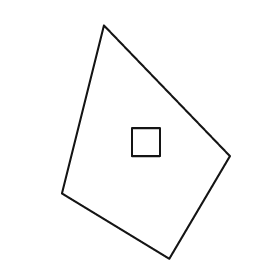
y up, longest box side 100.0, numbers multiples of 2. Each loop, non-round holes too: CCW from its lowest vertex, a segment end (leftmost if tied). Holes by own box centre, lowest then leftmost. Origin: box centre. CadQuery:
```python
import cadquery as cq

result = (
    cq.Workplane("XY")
    .moveTo(10.0, -50.0)
    .lineTo(36.0, -6.0)
    .lineTo(-18.0, 50.0)
    .lineTo(-36.0, -22.0)
    .close()
    .moveTo(-6.0, -6.0)
    .lineTo(6.0, -6.0)
    .lineTo(6.0, 6.0)
    .lineTo(-6.0, 6.0)
    .close()
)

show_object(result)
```